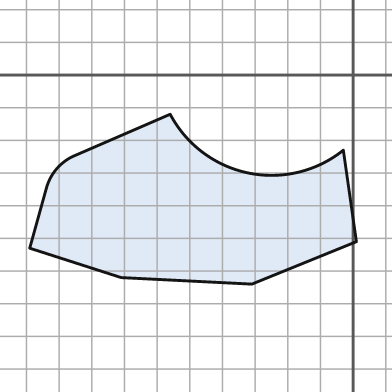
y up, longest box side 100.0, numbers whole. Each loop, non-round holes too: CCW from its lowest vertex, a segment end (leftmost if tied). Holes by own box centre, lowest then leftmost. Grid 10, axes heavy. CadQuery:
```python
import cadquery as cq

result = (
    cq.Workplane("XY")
    .moveTo(-31.0, -64.0)
    .lineTo(1.0, -51.0)
    .lineTo(-3.0, -23.0)
    .threePointArc((-32.0, -30.0), (-56.0, -12.0))
    .lineTo(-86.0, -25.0)
    .threePointArc((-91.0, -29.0), (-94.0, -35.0))
    .lineTo(-99.0, -53.0)
    .lineTo(-71.0, -62.0)
    .close()
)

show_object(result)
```